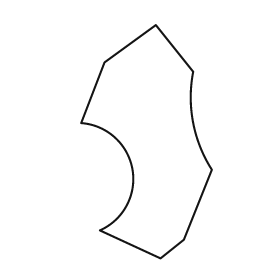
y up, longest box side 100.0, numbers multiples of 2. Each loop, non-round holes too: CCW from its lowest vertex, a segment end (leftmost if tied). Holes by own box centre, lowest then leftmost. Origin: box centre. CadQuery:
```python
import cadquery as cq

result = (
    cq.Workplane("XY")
    .moveTo(6.0, -50.0)
    .lineTo(16.0, -42.0)
    .lineTo(28.0, -12.0)
    .threePointArc((20.0, 8.0), (20.0, 30.0))
    .lineTo(4.0, 50.0)
    .lineTo(-18.0, 34.0)
    .lineTo(-28.0, 8.0)
    .threePointArc((-6.0, -12.0), (-20.0, -38.0))
    .close()
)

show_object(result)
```